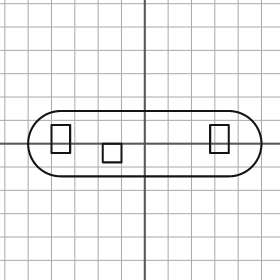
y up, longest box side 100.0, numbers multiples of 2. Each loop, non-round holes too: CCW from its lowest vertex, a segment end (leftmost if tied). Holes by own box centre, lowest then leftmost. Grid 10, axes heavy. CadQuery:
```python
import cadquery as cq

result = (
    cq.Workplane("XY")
    .moveTo(-36.0, -14.0)
    .lineTo(36.0, -14.0)
    .threePointArc((50.0, 0.0), (36.0, 14.0))
    .lineTo(-36.0, 14.0)
    .threePointArc((-50.0, 0.0), (-36.0, -14.0))
    .close()
    .moveTo(-18.0, -8.0)
    .lineTo(-10.0, -8.0)
    .lineTo(-10.0, 0.0)
    .lineTo(-18.0, 0.0)
    .close()
    .moveTo(-40.0, -4.0)
    .lineTo(-32.0, -4.0)
    .lineTo(-32.0, 8.0)
    .lineTo(-40.0, 8.0)
    .close()
    .moveTo(28.0, -4.0)
    .lineTo(36.0, -4.0)
    .lineTo(36.0, 8.0)
    .lineTo(28.0, 8.0)
    .close()
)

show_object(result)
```